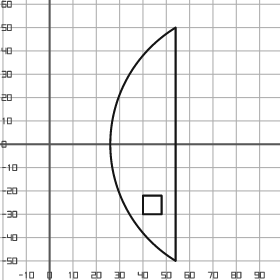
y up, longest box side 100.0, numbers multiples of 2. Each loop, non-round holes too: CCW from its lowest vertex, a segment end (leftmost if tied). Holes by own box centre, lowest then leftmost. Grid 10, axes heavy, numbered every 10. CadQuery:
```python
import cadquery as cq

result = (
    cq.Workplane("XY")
    .moveTo(54.0, -50.0)
    .lineTo(54.0, 50.0)
    .threePointArc((26.0, 0.0), (54.0, -50.0))
    .close()
    .moveTo(40.0, -30.0)
    .lineTo(48.0, -30.0)
    .lineTo(48.0, -22.0)
    .lineTo(40.0, -22.0)
    .close()
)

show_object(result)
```